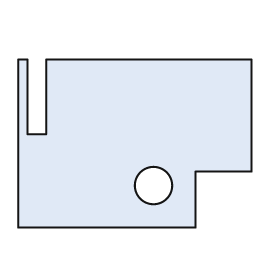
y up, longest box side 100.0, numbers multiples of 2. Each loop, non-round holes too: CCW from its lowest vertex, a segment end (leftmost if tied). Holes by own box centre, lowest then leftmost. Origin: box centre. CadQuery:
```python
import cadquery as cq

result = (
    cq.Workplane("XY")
    .moveTo(-50.0, -36.0)
    .lineTo(26.0, -36.0)
    .lineTo(26.0, -12.0)
    .lineTo(50.0, -12.0)
    .lineTo(50.0, 36.0)
    .lineTo(-38.0, 36.0)
    .lineTo(-38.0, 4.0)
    .lineTo(-46.0, 4.0)
    .lineTo(-46.0, 36.0)
    .lineTo(-50.0, 36.0)
    .close()
    .moveTo(8.0, -18.0)
    .circle(8.0)
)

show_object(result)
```